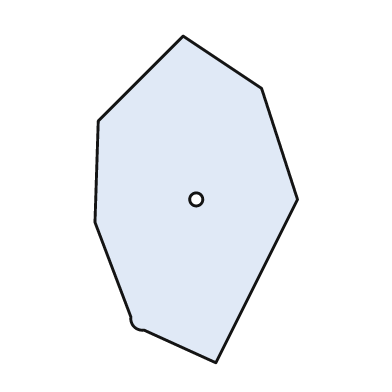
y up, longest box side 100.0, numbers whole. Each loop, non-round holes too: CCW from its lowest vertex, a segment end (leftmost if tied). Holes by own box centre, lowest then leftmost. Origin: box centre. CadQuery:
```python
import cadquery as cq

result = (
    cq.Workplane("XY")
    .moveTo(6.0, -50.0)
    .lineTo(31.0, 0.0)
    .lineTo(20.0, 34.0)
    .lineTo(-4.0, 50.0)
    .lineTo(-30.0, 24.0)
    .lineTo(-31.0, -7.0)
    .lineTo(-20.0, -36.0)
    .threePointArc((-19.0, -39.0), (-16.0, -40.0))
    .close()
    .moveTo(0.0, 0.0)
    .circle(2.0)
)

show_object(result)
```